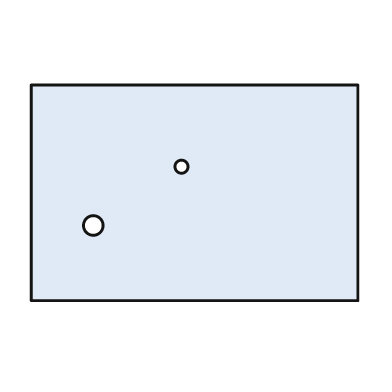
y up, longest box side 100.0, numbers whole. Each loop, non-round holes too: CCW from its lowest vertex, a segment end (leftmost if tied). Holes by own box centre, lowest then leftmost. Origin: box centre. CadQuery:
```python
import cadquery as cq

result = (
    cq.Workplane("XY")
    .moveTo(-50.0, -33.0)
    .lineTo(50.0, -33.0)
    .lineTo(50.0, 33.0)
    .lineTo(-50.0, 33.0)
    .close()
    .moveTo(-31.0, -10.0)
    .circle(3.0)
    .moveTo(-4.0, 8.0)
    .circle(2.0)
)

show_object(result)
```